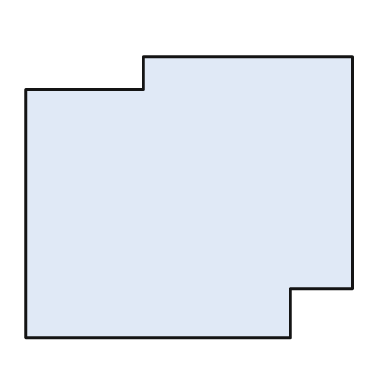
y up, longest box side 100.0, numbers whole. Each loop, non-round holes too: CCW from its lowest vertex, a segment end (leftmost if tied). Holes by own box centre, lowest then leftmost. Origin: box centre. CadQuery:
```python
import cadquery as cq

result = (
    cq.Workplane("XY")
    .moveTo(-50.0, -43.0)
    .lineTo(31.0, -43.0)
    .lineTo(31.0, -28.0)
    .lineTo(50.0, -28.0)
    .lineTo(50.0, 43.0)
    .lineTo(-14.0, 43.0)
    .lineTo(-14.0, 33.0)
    .lineTo(-50.0, 33.0)
    .close()
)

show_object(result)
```